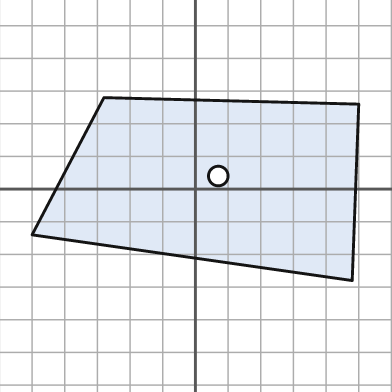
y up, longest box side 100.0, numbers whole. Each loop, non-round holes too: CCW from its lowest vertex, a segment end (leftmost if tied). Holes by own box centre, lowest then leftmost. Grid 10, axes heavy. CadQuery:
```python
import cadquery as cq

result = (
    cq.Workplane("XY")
    .moveTo(48.0, -28.0)
    .lineTo(50.0, 26.0)
    .lineTo(-28.0, 28.0)
    .lineTo(-50.0, -14.0)
    .close()
    .moveTo(7.0, 4.0)
    .circle(3.0)
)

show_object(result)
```